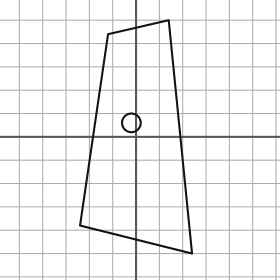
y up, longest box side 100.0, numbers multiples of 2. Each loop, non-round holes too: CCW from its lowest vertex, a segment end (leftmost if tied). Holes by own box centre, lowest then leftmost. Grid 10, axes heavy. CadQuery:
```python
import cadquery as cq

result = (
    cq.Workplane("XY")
    .moveTo(24.0, -50.0)
    .lineTo(14.0, 50.0)
    .lineTo(-12.0, 44.0)
    .lineTo(-24.0, -38.0)
    .close()
    .moveTo(-2.0, 6.0)
    .circle(4.0)
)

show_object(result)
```